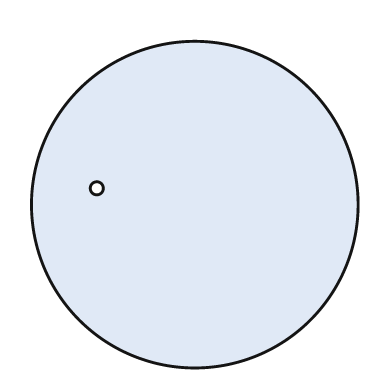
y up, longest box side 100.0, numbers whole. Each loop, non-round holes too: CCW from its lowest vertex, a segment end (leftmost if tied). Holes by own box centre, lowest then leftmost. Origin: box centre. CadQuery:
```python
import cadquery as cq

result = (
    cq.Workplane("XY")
    .moveTo(0.0, 0.0)
    .circle(50.0)
    .moveTo(-30.0, 5.0)
    .circle(2.0)
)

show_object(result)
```